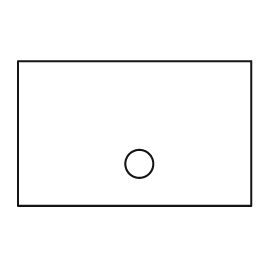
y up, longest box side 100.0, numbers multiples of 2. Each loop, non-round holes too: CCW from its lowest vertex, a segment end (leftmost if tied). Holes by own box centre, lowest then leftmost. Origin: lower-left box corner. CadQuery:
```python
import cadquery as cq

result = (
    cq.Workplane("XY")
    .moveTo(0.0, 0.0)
    .lineTo(100.0, 0.0)
    .lineTo(100.0, 62.0)
    .lineTo(0.0, 62.0)
    .close()
    .moveTo(52.0, 18.0)
    .circle(6.0)
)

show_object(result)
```